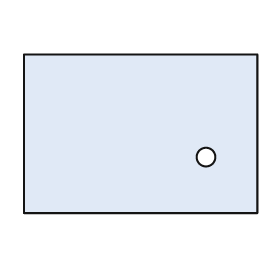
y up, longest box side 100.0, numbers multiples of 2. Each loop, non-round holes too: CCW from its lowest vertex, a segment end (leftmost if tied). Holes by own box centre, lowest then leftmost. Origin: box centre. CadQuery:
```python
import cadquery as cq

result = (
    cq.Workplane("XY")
    .moveTo(-50.0, -34.0)
    .lineTo(50.0, -34.0)
    .lineTo(50.0, 34.0)
    .lineTo(-50.0, 34.0)
    .close()
    .moveTo(28.0, -10.0)
    .circle(4.0)
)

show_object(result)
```